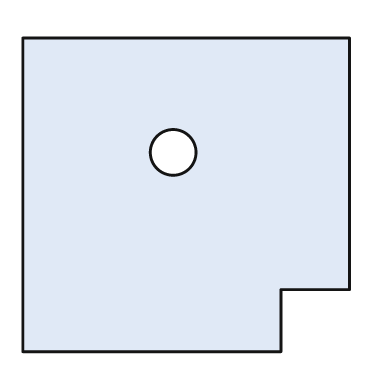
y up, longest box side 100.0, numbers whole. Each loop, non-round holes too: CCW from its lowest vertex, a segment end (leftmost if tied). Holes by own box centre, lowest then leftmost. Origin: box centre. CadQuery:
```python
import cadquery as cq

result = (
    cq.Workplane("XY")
    .moveTo(-50.0, -48.0)
    .lineTo(29.0, -48.0)
    .lineTo(29.0, -29.0)
    .lineTo(50.0, -29.0)
    .lineTo(50.0, 48.0)
    .lineTo(-50.0, 48.0)
    .close()
    .moveTo(-4.0, 13.0)
    .circle(7.0)
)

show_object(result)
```